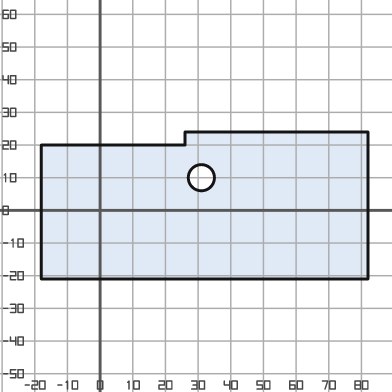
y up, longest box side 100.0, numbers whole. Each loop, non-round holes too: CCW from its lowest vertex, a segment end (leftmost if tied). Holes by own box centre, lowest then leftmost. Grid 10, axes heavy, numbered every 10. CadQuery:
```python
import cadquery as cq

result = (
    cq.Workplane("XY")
    .moveTo(-18.0, -21.0)
    .lineTo(82.0, -21.0)
    .lineTo(82.0, 24.0)
    .lineTo(26.0, 24.0)
    .lineTo(26.0, 20.0)
    .lineTo(-18.0, 20.0)
    .close()
    .moveTo(31.0, 10.0)
    .circle(4.0)
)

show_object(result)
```